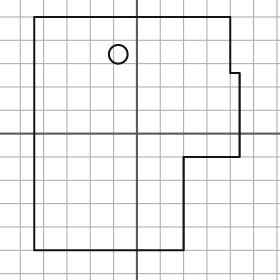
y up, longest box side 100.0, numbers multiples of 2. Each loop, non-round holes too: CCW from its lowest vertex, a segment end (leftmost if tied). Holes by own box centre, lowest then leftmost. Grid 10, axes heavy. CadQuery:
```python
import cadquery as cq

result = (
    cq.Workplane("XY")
    .moveTo(-44.0, -50.0)
    .lineTo(20.0, -50.0)
    .lineTo(20.0, -10.0)
    .lineTo(44.0, -10.0)
    .lineTo(44.0, 26.0)
    .lineTo(40.0, 26.0)
    .lineTo(40.0, 50.0)
    .lineTo(-44.0, 50.0)
    .close()
    .moveTo(-8.0, 34.0)
    .circle(4.0)
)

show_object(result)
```